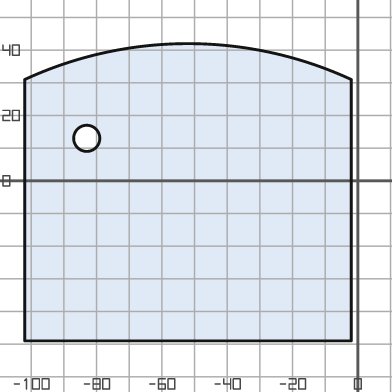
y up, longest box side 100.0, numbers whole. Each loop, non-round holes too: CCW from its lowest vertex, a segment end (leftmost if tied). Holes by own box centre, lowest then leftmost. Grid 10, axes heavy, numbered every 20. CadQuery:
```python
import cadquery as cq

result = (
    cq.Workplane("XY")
    .moveTo(-102.0, -49.0)
    .lineTo(-2.0, -49.0)
    .lineTo(-2.0, 31.0)
    .threePointArc((-52.0, 42.0), (-102.0, 31.0))
    .close()
    .moveTo(-83.0, 13.0)
    .circle(4.0)
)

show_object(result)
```